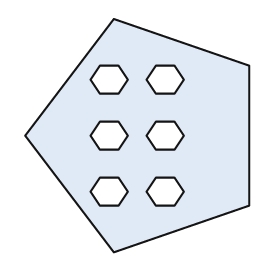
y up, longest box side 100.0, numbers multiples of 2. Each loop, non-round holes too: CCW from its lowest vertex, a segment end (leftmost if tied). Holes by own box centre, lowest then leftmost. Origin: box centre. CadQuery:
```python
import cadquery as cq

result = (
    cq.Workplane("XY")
    .moveTo(-10.0, -50.0)
    .lineTo(48.0, -30.0)
    .lineTo(48.0, 30.0)
    .lineTo(-10.0, 50.0)
    .lineTo(-48.0, 0.0)
    .close()
    .moveTo(-16.0, -30.0)
    .lineTo(-8.0, -30.0)
    .lineTo(-4.0, -24.0)
    .lineTo(-8.0, -18.0)
    .lineTo(-16.0, -18.0)
    .lineTo(-20.0, -24.0)
    .close()
    .moveTo(8.0, -30.0)
    .lineTo(16.0, -30.0)
    .lineTo(20.0, -24.0)
    .lineTo(16.0, -18.0)
    .lineTo(8.0, -18.0)
    .lineTo(4.0, -24.0)
    .close()
    .moveTo(-16.0, -6.0)
    .lineTo(-8.0, -6.0)
    .lineTo(-4.0, 0.0)
    .lineTo(-8.0, 6.0)
    .lineTo(-16.0, 6.0)
    .lineTo(-20.0, 0.0)
    .close()
    .moveTo(8.0, -6.0)
    .lineTo(16.0, -6.0)
    .lineTo(20.0, 0.0)
    .lineTo(16.0, 6.0)
    .lineTo(8.0, 6.0)
    .lineTo(4.0, 0.0)
    .close()
    .moveTo(-16.0, 18.0)
    .lineTo(-8.0, 18.0)
    .lineTo(-4.0, 24.0)
    .lineTo(-8.0, 30.0)
    .lineTo(-16.0, 30.0)
    .lineTo(-20.0, 24.0)
    .close()
    .moveTo(8.0, 18.0)
    .lineTo(16.0, 18.0)
    .lineTo(20.0, 24.0)
    .lineTo(16.0, 30.0)
    .lineTo(8.0, 30.0)
    .lineTo(4.0, 24.0)
    .close()
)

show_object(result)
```